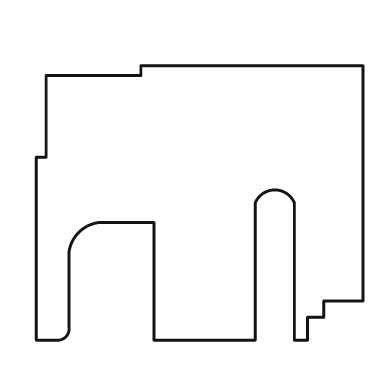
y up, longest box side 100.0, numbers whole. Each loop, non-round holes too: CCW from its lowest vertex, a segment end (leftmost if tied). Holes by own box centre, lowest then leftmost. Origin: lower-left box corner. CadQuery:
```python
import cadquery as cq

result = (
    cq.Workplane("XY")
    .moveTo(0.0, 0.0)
    .lineTo(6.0, 0.0)
    .threePointArc((9.0, 1.0), (10.0, 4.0))
    .lineTo(10.0, 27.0)
    .threePointArc((13.0, 33.0), (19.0, 36.0))
    .lineTo(36.0, 36.0)
    .lineTo(36.0, 0.0)
    .lineTo(67.0, 0.0)
    .lineTo(67.0, 42.0)
    .threePointArc((73.0, 46.0), (79.0, 42.0))
    .lineTo(79.0, 0.0)
    .lineTo(83.0, 0.0)
    .lineTo(83.0, 7.0)
    .lineTo(88.0, 7.0)
    .lineTo(88.0, 12.0)
    .lineTo(100.0, 12.0)
    .lineTo(100.0, 84.0)
    .lineTo(32.0, 84.0)
    .lineTo(32.0, 81.0)
    .lineTo(3.0, 81.0)
    .lineTo(3.0, 56.0)
    .lineTo(0.0, 56.0)
    .close()
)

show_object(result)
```